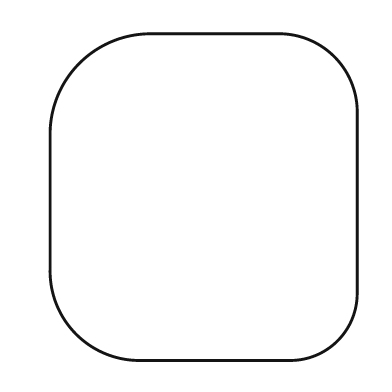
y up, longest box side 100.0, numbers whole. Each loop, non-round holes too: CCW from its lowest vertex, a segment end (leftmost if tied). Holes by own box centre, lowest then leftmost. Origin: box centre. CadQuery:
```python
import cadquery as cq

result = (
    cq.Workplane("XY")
    .moveTo(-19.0, -50.0)
    .lineTo(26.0, -50.0)
    .threePointArc((41.0, -44.0), (47.0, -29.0))
    .lineTo(47.0, 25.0)
    .threePointArc((40.0, 43.0), (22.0, 50.0))
    .lineTo(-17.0, 50.0)
    .threePointArc((-38.0, 41.0), (-47.0, 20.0))
    .lineTo(-47.0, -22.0)
    .threePointArc((-39.0, -42.0), (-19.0, -50.0))
    .close()
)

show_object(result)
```